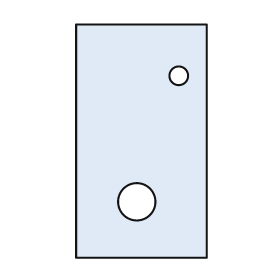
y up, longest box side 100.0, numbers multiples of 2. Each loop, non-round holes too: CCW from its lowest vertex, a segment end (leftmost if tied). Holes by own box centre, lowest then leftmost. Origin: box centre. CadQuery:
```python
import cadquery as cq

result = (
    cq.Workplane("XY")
    .moveTo(-28.0, -50.0)
    .lineTo(28.0, -50.0)
    .lineTo(28.0, 50.0)
    .lineTo(-28.0, 50.0)
    .close()
    .moveTo(-2.0, -26.0)
    .circle(8.0)
    .moveTo(16.0, 28.0)
    .circle(4.0)
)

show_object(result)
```